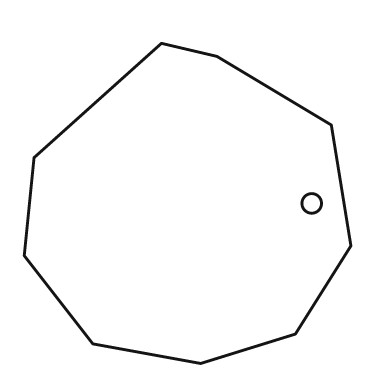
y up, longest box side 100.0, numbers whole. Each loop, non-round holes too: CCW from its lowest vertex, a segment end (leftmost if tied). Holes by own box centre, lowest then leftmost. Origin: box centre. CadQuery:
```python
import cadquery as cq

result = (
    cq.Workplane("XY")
    .moveTo(4.0, -49.0)
    .lineTo(33.0, -40.0)
    .lineTo(50.0, -13.0)
    .lineTo(44.0, 24.0)
    .lineTo(9.0, 45.0)
    .lineTo(-8.0, 49.0)
    .lineTo(-47.0, 14.0)
    .lineTo(-50.0, -16.0)
    .lineTo(-29.0, -43.0)
    .close()
    .moveTo(38.0, 0.0)
    .circle(3.0)
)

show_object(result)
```